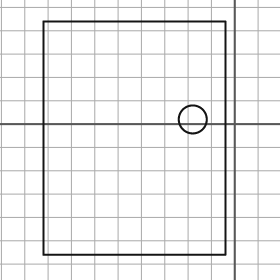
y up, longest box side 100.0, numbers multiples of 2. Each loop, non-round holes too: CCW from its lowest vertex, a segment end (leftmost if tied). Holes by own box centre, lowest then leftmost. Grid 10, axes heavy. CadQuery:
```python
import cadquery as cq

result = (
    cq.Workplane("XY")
    .moveTo(-82.0, -56.0)
    .lineTo(-4.0, -56.0)
    .lineTo(-4.0, 44.0)
    .lineTo(-82.0, 44.0)
    .close()
    .moveTo(-18.0, 2.0)
    .circle(6.0)
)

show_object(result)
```